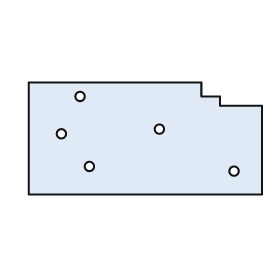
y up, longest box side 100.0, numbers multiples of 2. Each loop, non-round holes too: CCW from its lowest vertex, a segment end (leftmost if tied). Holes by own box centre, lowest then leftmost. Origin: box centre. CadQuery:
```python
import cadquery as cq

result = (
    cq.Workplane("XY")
    .moveTo(-50.0, -24.0)
    .lineTo(50.0, -24.0)
    .lineTo(50.0, 14.0)
    .lineTo(32.0, 14.0)
    .lineTo(32.0, 18.0)
    .lineTo(24.0, 18.0)
    .lineTo(24.0, 24.0)
    .lineTo(-50.0, 24.0)
    .close()
    .moveTo(38.0, -14.0)
    .circle(2.0)
    .moveTo(-24.0, -12.0)
    .circle(2.0)
    .moveTo(-36.0, 2.0)
    .circle(2.0)
    .moveTo(6.0, 4.0)
    .circle(2.0)
    .moveTo(-28.0, 18.0)
    .circle(2.0)
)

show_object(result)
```